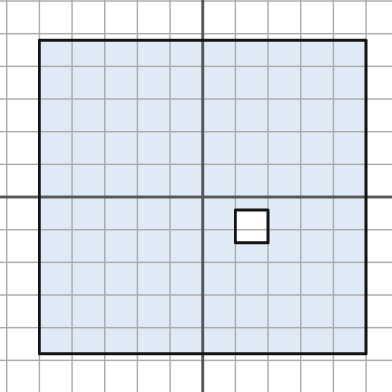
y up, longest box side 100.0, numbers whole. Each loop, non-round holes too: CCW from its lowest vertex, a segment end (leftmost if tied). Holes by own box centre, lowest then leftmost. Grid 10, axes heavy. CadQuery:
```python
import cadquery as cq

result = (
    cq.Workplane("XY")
    .moveTo(-50.0, -48.0)
    .lineTo(50.0, -48.0)
    .lineTo(50.0, 48.0)
    .lineTo(-50.0, 48.0)
    .close()
    .moveTo(10.0, -14.0)
    .lineTo(20.0, -14.0)
    .lineTo(20.0, -4.0)
    .lineTo(10.0, -4.0)
    .close()
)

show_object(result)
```